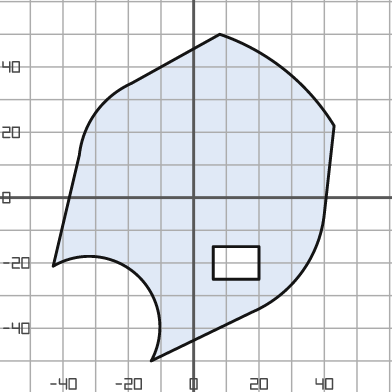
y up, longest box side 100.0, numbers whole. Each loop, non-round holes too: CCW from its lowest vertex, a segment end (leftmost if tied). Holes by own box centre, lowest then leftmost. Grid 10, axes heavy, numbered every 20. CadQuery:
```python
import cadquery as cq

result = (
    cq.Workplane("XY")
    .moveTo(-13.0, -50.0)
    .lineTo(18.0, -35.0)
    .threePointArc((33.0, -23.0), (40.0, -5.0))
    .lineTo(43.0, 22.0)
    .threePointArc((28.0, 39.0), (8.0, 50.0))
    .lineTo(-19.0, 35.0)
    .threePointArc((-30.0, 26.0), (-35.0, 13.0))
    .lineTo(-43.0, -21.0)
    .threePointArc((-17.0, -24.0), (-13.0, -50.0))
    .close()
    .moveTo(6.0, -25.0)
    .lineTo(20.0, -25.0)
    .lineTo(20.0, -15.0)
    .lineTo(6.0, -15.0)
    .close()
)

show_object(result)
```